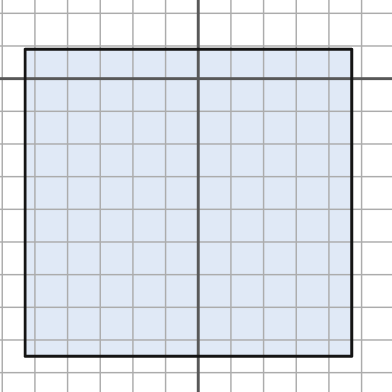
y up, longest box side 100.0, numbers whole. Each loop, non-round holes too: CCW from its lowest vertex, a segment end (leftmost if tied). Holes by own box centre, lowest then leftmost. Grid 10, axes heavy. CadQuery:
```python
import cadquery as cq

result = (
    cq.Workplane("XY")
    .moveTo(-53.0, -85.0)
    .lineTo(47.0, -85.0)
    .lineTo(47.0, 9.0)
    .lineTo(-53.0, 9.0)
    .close()
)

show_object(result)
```